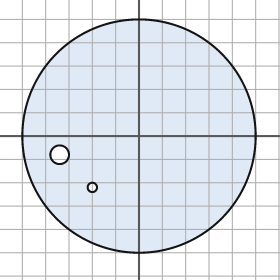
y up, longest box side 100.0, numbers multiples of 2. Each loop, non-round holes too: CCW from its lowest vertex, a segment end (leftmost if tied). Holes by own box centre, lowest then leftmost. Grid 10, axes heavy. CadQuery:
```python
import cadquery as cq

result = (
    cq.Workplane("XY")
    .moveTo(0.0, 0.0)
    .circle(50.0)
    .moveTo(-20.0, -22.0)
    .circle(2.0)
    .moveTo(-34.0, -8.0)
    .circle(4.0)
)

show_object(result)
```